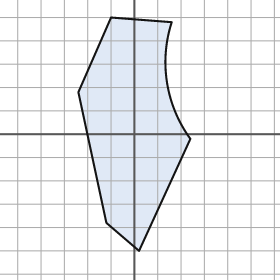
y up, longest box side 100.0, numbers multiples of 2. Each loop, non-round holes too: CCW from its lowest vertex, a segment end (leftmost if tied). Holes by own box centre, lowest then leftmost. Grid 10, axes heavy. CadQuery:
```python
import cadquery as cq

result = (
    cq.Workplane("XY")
    .moveTo(2.0, -50.0)
    .lineTo(24.0, -2.0)
    .threePointArc((14.0, 22.0), (16.0, 48.0))
    .lineTo(-10.0, 50.0)
    .lineTo(-24.0, 18.0)
    .lineTo(-12.0, -38.0)
    .close()
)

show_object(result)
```